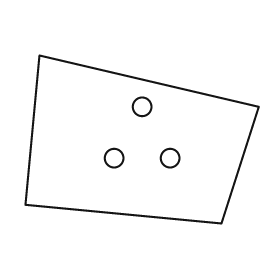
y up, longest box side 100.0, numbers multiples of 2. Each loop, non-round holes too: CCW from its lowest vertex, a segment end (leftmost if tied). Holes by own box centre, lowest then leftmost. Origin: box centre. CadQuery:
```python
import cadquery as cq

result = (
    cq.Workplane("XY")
    .moveTo(34.0, -36.0)
    .lineTo(50.0, 14.0)
    .lineTo(-44.0, 36.0)
    .lineTo(-50.0, -28.0)
    .close()
    .moveTo(-12.0, -8.0)
    .circle(4.0)
    .moveTo(12.0, -8.0)
    .circle(4.0)
    .moveTo(0.0, 14.0)
    .circle(4.0)
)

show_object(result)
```